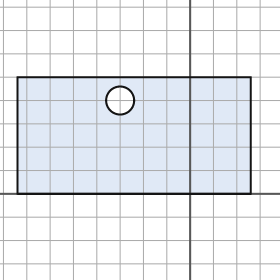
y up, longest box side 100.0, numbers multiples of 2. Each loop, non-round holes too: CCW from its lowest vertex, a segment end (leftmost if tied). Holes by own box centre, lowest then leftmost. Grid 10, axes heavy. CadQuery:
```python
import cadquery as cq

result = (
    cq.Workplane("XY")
    .moveTo(-74.0, 0.0)
    .lineTo(26.0, 0.0)
    .lineTo(26.0, 50.0)
    .lineTo(-74.0, 50.0)
    .close()
    .moveTo(-30.0, 40.0)
    .circle(6.0)
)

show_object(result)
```